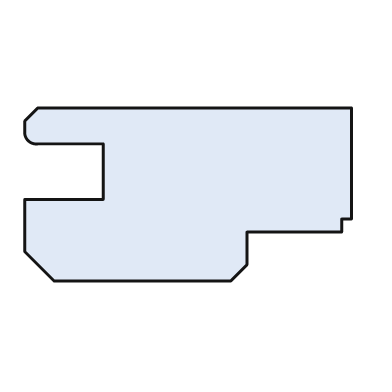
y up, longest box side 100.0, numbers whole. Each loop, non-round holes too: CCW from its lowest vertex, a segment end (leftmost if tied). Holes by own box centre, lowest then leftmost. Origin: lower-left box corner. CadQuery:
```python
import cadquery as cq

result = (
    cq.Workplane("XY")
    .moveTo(9.0, 0.0)
    .lineTo(63.0, 0.0)
    .lineTo(68.0, 5.0)
    .lineTo(68.0, 15.0)
    .lineTo(97.0, 15.0)
    .lineTo(97.0, 19.0)
    .lineTo(100.0, 19.0)
    .lineTo(100.0, 53.0)
    .lineTo(4.0, 53.0)
    .lineTo(0.0, 49.0)
    .lineTo(0.0, 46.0)
    .threePointArc((1.0, 43.0), (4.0, 42.0))
    .lineTo(24.0, 42.0)
    .lineTo(24.0, 25.0)
    .lineTo(0.0, 25.0)
    .lineTo(0.0, 9.0)
    .close()
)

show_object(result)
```